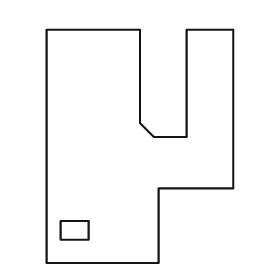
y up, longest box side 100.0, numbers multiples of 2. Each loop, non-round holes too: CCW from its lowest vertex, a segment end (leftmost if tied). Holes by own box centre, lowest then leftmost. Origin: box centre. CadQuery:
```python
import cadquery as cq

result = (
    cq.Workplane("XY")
    .moveTo(-40.0, -50.0)
    .lineTo(8.0, -50.0)
    .lineTo(8.0, -18.0)
    .lineTo(40.0, -18.0)
    .lineTo(40.0, 50.0)
    .lineTo(20.0, 50.0)
    .lineTo(20.0, 4.0)
    .lineTo(6.0, 4.0)
    .lineTo(0.0, 10.0)
    .lineTo(0.0, 50.0)
    .lineTo(-40.0, 50.0)
    .close()
    .moveTo(-34.0, -40.0)
    .lineTo(-22.0, -40.0)
    .lineTo(-22.0, -32.0)
    .lineTo(-34.0, -32.0)
    .close()
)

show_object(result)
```